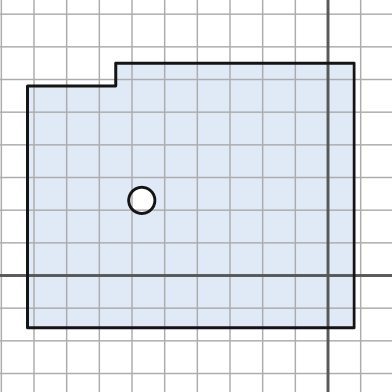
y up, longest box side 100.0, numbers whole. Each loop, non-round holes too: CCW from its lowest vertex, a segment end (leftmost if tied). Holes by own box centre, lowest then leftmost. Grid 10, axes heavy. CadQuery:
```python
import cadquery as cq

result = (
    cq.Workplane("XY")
    .moveTo(-92.0, -16.0)
    .lineTo(8.0, -16.0)
    .lineTo(8.0, 65.0)
    .lineTo(-65.0, 65.0)
    .lineTo(-65.0, 58.0)
    .lineTo(-92.0, 58.0)
    .close()
    .moveTo(-57.0, 23.0)
    .circle(4.0)
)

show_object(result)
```